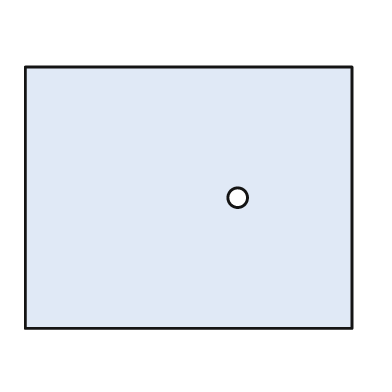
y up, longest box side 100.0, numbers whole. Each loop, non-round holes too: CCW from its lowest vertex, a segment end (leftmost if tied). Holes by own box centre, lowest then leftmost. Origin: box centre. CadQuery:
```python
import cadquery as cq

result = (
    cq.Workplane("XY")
    .moveTo(-50.0, -40.0)
    .lineTo(50.0, -40.0)
    .lineTo(50.0, 40.0)
    .lineTo(-50.0, 40.0)
    .close()
    .moveTo(15.0, 0.0)
    .circle(3.0)
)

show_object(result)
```